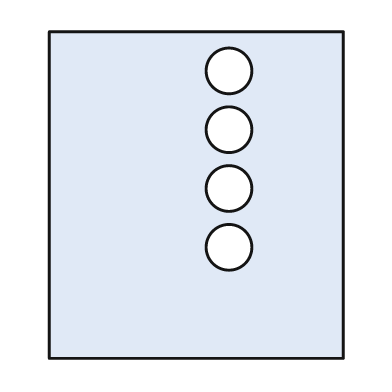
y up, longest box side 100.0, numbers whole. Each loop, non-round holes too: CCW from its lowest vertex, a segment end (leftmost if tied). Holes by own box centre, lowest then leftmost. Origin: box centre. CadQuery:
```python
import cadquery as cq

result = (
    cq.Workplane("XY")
    .moveTo(-45.0, -50.0)
    .lineTo(45.0, -50.0)
    .lineTo(45.0, 50.0)
    .lineTo(-45.0, 50.0)
    .close()
    .moveTo(10.0, -16.0)
    .circle(7.0)
    .moveTo(10.0, 2.0)
    .circle(7.0)
    .moveTo(10.0, 20.0)
    .circle(7.0)
    .moveTo(10.0, 38.0)
    .circle(7.0)
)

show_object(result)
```